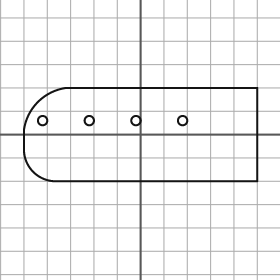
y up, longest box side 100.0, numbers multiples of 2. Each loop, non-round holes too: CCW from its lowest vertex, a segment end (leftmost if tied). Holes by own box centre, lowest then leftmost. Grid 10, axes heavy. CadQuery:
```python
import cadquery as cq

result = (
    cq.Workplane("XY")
    .moveTo(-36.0, -20.0)
    .lineTo(50.0, -20.0)
    .lineTo(50.0, 20.0)
    .lineTo(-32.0, 20.0)
    .threePointArc((-44.0, 14.0), (-50.0, 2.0))
    .lineTo(-50.0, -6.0)
    .threePointArc((-46.0, -16.0), (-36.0, -20.0))
    .close()
    .moveTo(-42.0, 6.0)
    .circle(2.0)
    .moveTo(-22.0, 6.0)
    .circle(2.0)
    .moveTo(-2.0, 6.0)
    .circle(2.0)
    .moveTo(18.0, 6.0)
    .circle(2.0)
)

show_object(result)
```